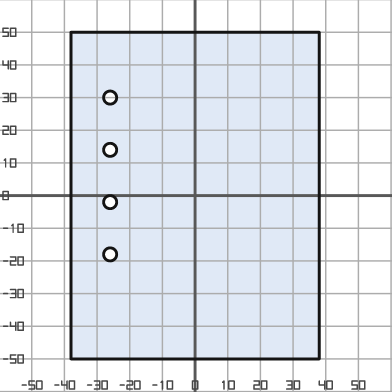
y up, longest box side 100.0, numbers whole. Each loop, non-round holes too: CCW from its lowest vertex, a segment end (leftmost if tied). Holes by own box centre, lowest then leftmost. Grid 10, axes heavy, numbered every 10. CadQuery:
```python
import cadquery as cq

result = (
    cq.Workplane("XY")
    .moveTo(-38.0, -50.0)
    .lineTo(38.0, -50.0)
    .lineTo(38.0, 50.0)
    .lineTo(-38.0, 50.0)
    .close()
    .moveTo(-26.0, -18.0)
    .circle(2.0)
    .moveTo(-26.0, -2.0)
    .circle(2.0)
    .moveTo(-26.0, 14.0)
    .circle(2.0)
    .moveTo(-26.0, 30.0)
    .circle(2.0)
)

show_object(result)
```